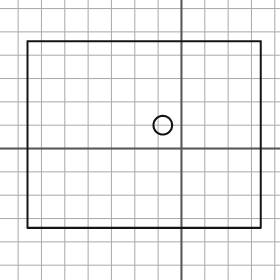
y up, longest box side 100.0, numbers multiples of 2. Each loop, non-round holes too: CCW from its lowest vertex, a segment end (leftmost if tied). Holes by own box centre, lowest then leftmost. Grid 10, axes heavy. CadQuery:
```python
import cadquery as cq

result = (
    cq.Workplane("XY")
    .moveTo(-66.0, -34.0)
    .lineTo(34.0, -34.0)
    .lineTo(34.0, 46.0)
    .lineTo(-66.0, 46.0)
    .close()
    .moveTo(-8.0, 10.0)
    .circle(4.0)
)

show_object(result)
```